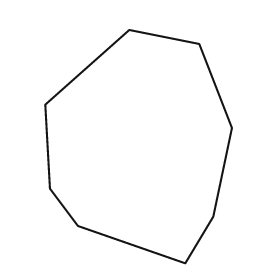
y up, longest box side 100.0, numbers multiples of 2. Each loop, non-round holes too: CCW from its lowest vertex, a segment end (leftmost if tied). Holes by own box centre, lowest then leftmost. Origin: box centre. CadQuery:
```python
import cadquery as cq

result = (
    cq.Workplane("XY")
    .moveTo(20.0, -50.0)
    .lineTo(32.0, -30.0)
    .lineTo(40.0, 8.0)
    .lineTo(26.0, 44.0)
    .lineTo(-4.0, 50.0)
    .lineTo(-40.0, 18.0)
    .lineTo(-38.0, -18.0)
    .lineTo(-26.0, -34.0)
    .close()
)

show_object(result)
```